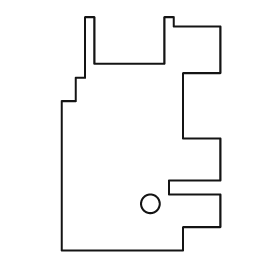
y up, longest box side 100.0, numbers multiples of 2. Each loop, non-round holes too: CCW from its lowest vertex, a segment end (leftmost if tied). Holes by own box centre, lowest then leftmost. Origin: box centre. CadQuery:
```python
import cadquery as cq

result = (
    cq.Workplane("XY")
    .moveTo(-34.0, -50.0)
    .lineTo(18.0, -50.0)
    .lineTo(18.0, -40.0)
    .lineTo(34.0, -40.0)
    .lineTo(34.0, -26.0)
    .lineTo(12.0, -26.0)
    .lineTo(12.0, -20.0)
    .lineTo(34.0, -20.0)
    .lineTo(34.0, -2.0)
    .lineTo(18.0, -2.0)
    .lineTo(18.0, 26.0)
    .lineTo(34.0, 26.0)
    .lineTo(34.0, 46.0)
    .lineTo(14.0, 46.0)
    .lineTo(14.0, 50.0)
    .lineTo(10.0, 50.0)
    .lineTo(10.0, 30.0)
    .lineTo(-20.0, 30.0)
    .lineTo(-20.0, 50.0)
    .lineTo(-24.0, 50.0)
    .lineTo(-24.0, 24.0)
    .lineTo(-28.0, 24.0)
    .lineTo(-28.0, 14.0)
    .lineTo(-34.0, 14.0)
    .close()
    .moveTo(4.0, -30.0)
    .circle(4.0)
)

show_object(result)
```